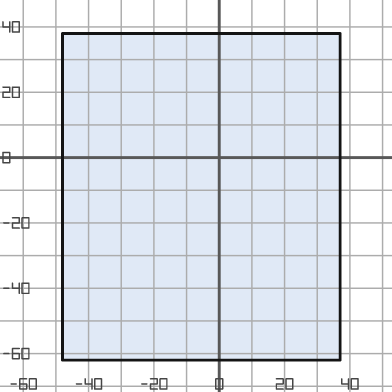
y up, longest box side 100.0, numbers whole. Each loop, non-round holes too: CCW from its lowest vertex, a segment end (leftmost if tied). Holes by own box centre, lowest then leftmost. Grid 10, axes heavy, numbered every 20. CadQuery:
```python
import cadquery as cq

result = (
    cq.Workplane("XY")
    .moveTo(-48.0, -62.0)
    .lineTo(37.0, -62.0)
    .lineTo(37.0, 38.0)
    .lineTo(-48.0, 38.0)
    .close()
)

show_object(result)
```